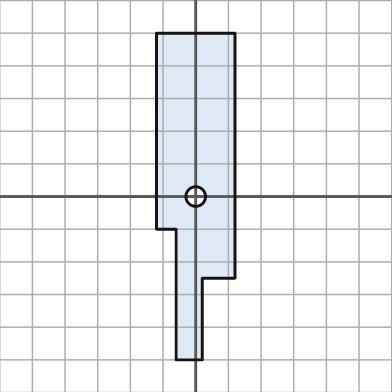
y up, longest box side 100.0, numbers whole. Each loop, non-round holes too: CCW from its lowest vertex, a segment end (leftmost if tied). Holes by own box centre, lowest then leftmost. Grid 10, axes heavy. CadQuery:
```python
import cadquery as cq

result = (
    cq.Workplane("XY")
    .moveTo(-6.0, -50.0)
    .lineTo(2.0, -50.0)
    .lineTo(2.0, -25.0)
    .lineTo(12.0, -25.0)
    .lineTo(12.0, 50.0)
    .lineTo(-12.0, 50.0)
    .lineTo(-12.0, -10.0)
    .lineTo(-6.0, -10.0)
    .close()
    .moveTo(0.0, 0.0)
    .circle(3.0)
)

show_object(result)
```